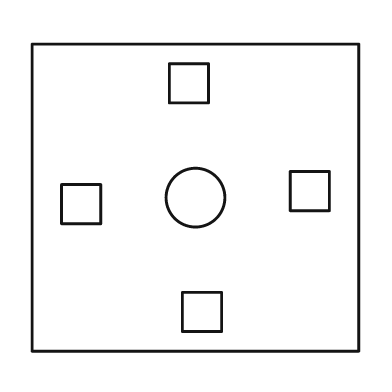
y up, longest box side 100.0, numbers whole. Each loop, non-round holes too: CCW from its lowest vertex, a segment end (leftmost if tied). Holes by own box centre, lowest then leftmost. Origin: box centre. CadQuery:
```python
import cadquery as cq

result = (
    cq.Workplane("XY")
    .moveTo(-50.0, -47.0)
    .lineTo(50.0, -47.0)
    .lineTo(50.0, 47.0)
    .lineTo(-50.0, 47.0)
    .close()
    .moveTo(-4.0, -41.0)
    .lineTo(8.0, -41.0)
    .lineTo(8.0, -29.0)
    .lineTo(-4.0, -29.0)
    .close()
    .moveTo(-41.0, -8.0)
    .lineTo(-29.0, -8.0)
    .lineTo(-29.0, 4.0)
    .lineTo(-41.0, 4.0)
    .close()
    .moveTo(0.0, 0.0)
    .circle(9.0)
    .moveTo(29.0, -4.0)
    .lineTo(41.0, -4.0)
    .lineTo(41.0, 8.0)
    .lineTo(29.0, 8.0)
    .close()
    .moveTo(-8.0, 29.0)
    .lineTo(4.0, 29.0)
    .lineTo(4.0, 41.0)
    .lineTo(-8.0, 41.0)
    .close()
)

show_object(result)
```